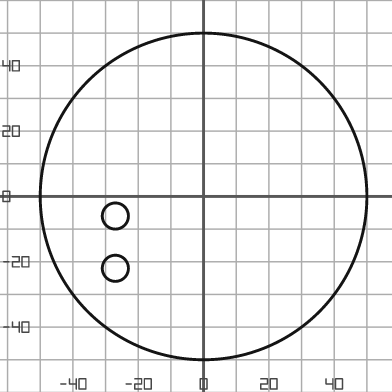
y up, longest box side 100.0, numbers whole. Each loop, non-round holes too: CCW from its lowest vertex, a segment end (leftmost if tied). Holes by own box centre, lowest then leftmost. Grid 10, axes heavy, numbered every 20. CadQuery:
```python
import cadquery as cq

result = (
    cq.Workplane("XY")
    .moveTo(0.0, 0.0)
    .circle(50.0)
    .moveTo(-27.0, -22.0)
    .circle(4.0)
    .moveTo(-27.0, -6.0)
    .circle(4.0)
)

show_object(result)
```